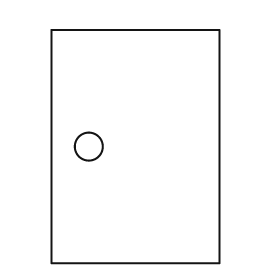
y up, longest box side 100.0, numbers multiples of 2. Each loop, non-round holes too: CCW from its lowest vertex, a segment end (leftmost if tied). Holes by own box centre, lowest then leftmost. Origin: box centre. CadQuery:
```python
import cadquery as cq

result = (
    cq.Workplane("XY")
    .moveTo(-36.0, -50.0)
    .lineTo(36.0, -50.0)
    .lineTo(36.0, 50.0)
    .lineTo(-36.0, 50.0)
    .close()
    .moveTo(-20.0, 0.0)
    .circle(6.0)
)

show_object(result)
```